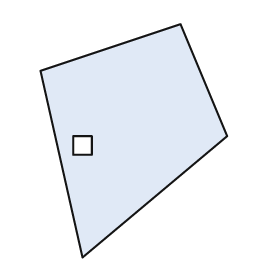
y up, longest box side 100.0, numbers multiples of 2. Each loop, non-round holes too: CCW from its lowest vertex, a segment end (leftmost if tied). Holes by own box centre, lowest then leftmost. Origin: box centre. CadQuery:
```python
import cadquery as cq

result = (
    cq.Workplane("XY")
    .moveTo(-22.0, -50.0)
    .lineTo(40.0, 2.0)
    .lineTo(20.0, 50.0)
    .lineTo(-40.0, 30.0)
    .close()
    .moveTo(-26.0, -6.0)
    .lineTo(-18.0, -6.0)
    .lineTo(-18.0, 2.0)
    .lineTo(-26.0, 2.0)
    .close()
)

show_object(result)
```